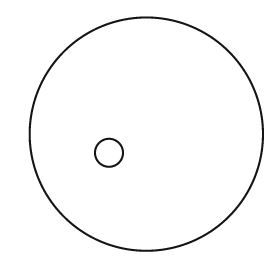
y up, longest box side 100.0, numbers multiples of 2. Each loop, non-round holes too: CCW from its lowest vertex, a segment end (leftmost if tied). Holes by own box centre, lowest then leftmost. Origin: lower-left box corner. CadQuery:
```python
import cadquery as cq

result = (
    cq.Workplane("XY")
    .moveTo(50.0, 50.0)
    .circle(50.0)
    .moveTo(34.0, 42.0)
    .circle(6.0)
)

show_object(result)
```